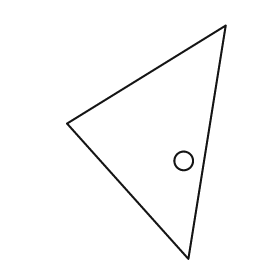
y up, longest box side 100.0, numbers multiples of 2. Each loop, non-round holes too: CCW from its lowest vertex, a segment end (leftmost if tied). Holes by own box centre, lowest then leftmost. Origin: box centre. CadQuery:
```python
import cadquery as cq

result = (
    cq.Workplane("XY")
    .moveTo(18.0, -50.0)
    .lineTo(34.0, 50.0)
    .lineTo(-34.0, 8.0)
    .close()
    .moveTo(16.0, -8.0)
    .circle(4.0)
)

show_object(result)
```